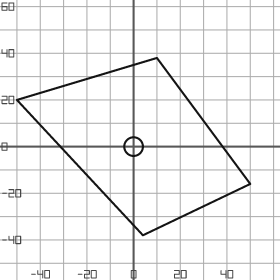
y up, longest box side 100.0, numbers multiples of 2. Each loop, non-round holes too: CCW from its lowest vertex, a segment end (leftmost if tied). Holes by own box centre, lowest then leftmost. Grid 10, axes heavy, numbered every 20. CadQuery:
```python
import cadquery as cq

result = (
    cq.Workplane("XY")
    .moveTo(4.0, -38.0)
    .lineTo(50.0, -16.0)
    .lineTo(10.0, 38.0)
    .lineTo(-50.0, 20.0)
    .close()
    .moveTo(0.0, 0.0)
    .circle(4.0)
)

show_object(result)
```